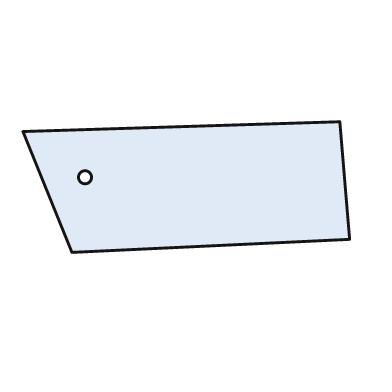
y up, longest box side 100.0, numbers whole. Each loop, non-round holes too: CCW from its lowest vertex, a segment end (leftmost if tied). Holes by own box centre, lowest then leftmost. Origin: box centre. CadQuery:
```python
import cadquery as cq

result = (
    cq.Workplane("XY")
    .moveTo(-35.0, -20.0)
    .lineTo(50.0, -16.0)
    .lineTo(47.0, 20.0)
    .lineTo(-50.0, 17.0)
    .close()
    .moveTo(-31.0, 3.0)
    .circle(2.0)
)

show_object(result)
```